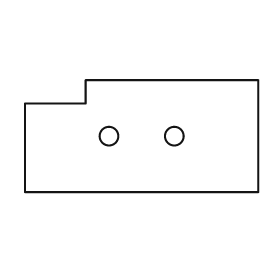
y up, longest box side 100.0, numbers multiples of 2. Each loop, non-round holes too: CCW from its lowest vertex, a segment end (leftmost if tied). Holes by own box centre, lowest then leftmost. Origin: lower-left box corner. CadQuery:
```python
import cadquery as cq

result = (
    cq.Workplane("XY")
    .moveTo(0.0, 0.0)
    .lineTo(100.0, 0.0)
    .lineTo(100.0, 48.0)
    .lineTo(26.0, 48.0)
    .lineTo(26.0, 38.0)
    .lineTo(0.0, 38.0)
    .close()
    .moveTo(36.0, 24.0)
    .circle(4.0)
    .moveTo(64.0, 24.0)
    .circle(4.0)
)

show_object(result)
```